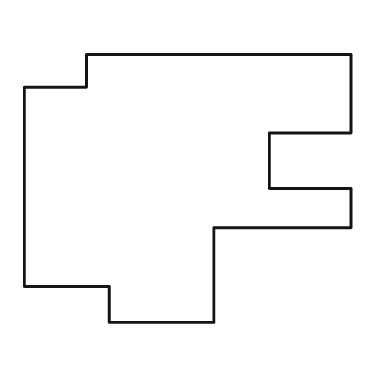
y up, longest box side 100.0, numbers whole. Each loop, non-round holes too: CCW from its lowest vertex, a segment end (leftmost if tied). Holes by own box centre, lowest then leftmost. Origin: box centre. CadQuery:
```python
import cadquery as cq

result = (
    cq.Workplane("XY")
    .moveTo(-24.0, -41.0)
    .lineTo(8.0, -41.0)
    .lineTo(8.0, -12.0)
    .lineTo(50.0, -12.0)
    .lineTo(50.0, 0.0)
    .lineTo(25.0, 0.0)
    .lineTo(25.0, 17.0)
    .lineTo(50.0, 17.0)
    .lineTo(50.0, 41.0)
    .lineTo(-31.0, 41.0)
    .lineTo(-31.0, 31.0)
    .lineTo(-50.0, 31.0)
    .lineTo(-50.0, -30.0)
    .lineTo(-24.0, -30.0)
    .close()
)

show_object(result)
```